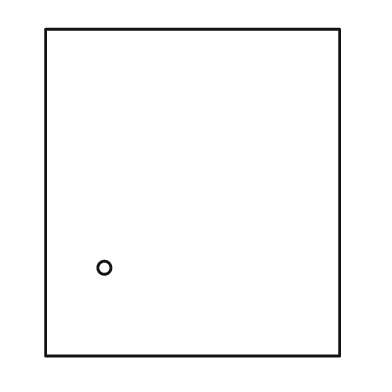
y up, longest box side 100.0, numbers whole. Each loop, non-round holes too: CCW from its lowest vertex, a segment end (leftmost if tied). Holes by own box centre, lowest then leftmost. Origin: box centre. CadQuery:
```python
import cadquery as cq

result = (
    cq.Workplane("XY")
    .moveTo(-45.0, -50.0)
    .lineTo(45.0, -50.0)
    .lineTo(45.0, 50.0)
    .lineTo(-45.0, 50.0)
    .close()
    .moveTo(-27.0, -23.0)
    .circle(2.0)
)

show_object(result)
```